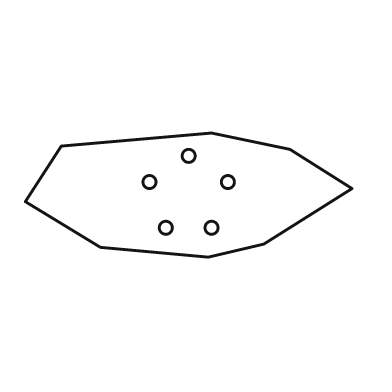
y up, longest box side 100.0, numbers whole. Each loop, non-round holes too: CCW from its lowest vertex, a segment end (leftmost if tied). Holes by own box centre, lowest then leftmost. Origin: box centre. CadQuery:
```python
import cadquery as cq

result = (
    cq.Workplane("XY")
    .moveTo(6.0, -19.0)
    .lineTo(23.0, -15.0)
    .lineTo(50.0, 2.0)
    .lineTo(31.0, 14.0)
    .lineTo(7.0, 19.0)
    .lineTo(-39.0, 15.0)
    .lineTo(-50.0, -2.0)
    .lineTo(-27.0, -16.0)
    .close()
    .moveTo(-7.0, -10.0)
    .circle(2.0)
    .moveTo(7.0, -10.0)
    .circle(2.0)
    .moveTo(-12.0, 4.0)
    .circle(2.0)
    .moveTo(12.0, 4.0)
    .circle(2.0)
    .moveTo(0.0, 12.0)
    .circle(2.0)
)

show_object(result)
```